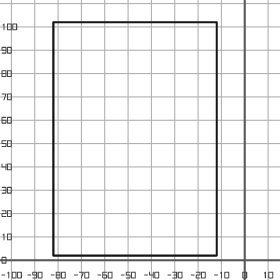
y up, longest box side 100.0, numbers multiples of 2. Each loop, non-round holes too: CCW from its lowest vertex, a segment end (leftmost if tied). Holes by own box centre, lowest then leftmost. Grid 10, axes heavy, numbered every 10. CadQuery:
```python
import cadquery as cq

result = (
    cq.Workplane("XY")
    .moveTo(-82.0, 2.0)
    .lineTo(-12.0, 2.0)
    .lineTo(-12.0, 102.0)
    .lineTo(-82.0, 102.0)
    .close()
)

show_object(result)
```